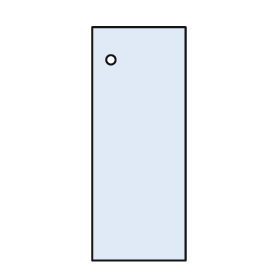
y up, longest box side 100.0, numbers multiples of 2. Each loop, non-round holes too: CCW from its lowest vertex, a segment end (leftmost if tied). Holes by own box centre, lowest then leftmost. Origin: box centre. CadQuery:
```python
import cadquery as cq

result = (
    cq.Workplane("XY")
    .moveTo(-20.0, -50.0)
    .lineTo(20.0, -50.0)
    .lineTo(20.0, 50.0)
    .lineTo(-20.0, 50.0)
    .close()
    .moveTo(-12.0, 36.0)
    .circle(2.0)
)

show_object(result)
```